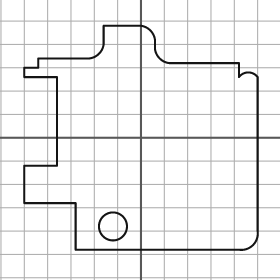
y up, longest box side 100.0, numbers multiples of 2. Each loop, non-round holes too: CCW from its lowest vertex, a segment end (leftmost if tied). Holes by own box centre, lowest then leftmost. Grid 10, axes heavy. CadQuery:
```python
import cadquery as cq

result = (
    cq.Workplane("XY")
    .moveTo(-28.0, -48.0)
    .lineTo(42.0, -48.0)
    .threePointArc((48.0, -46.0), (50.0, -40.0))
    .lineTo(50.0, 26.0)
    .threePointArc((46.0, 28.0), (42.0, 26.0))
    .lineTo(42.0, 32.0)
    .lineTo(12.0, 32.0)
    .threePointArc((8.0, 34.0), (6.0, 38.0))
    .lineTo(6.0, 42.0)
    .threePointArc((4.0, 46.0), (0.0, 48.0))
    .lineTo(-16.0, 48.0)
    .lineTo(-16.0, 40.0)
    .threePointArc((-18.0, 36.0), (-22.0, 34.0))
    .lineTo(-44.0, 34.0)
    .lineTo(-44.0, 30.0)
    .lineTo(-50.0, 30.0)
    .lineTo(-50.0, 26.0)
    .lineTo(-36.0, 26.0)
    .lineTo(-36.0, -12.0)
    .lineTo(-50.0, -12.0)
    .lineTo(-50.0, -28.0)
    .lineTo(-28.0, -28.0)
    .close()
    .moveTo(-12.0, -38.0)
    .circle(6.0)
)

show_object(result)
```